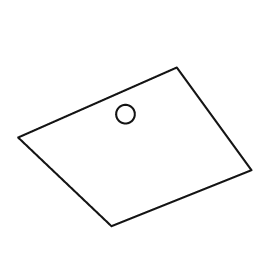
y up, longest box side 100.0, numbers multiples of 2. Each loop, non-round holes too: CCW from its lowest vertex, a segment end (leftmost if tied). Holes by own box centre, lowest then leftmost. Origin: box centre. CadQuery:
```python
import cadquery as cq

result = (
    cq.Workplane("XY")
    .moveTo(-10.0, -34.0)
    .lineTo(50.0, -10.0)
    .lineTo(18.0, 34.0)
    .lineTo(-50.0, 4.0)
    .close()
    .moveTo(-4.0, 14.0)
    .circle(4.0)
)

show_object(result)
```